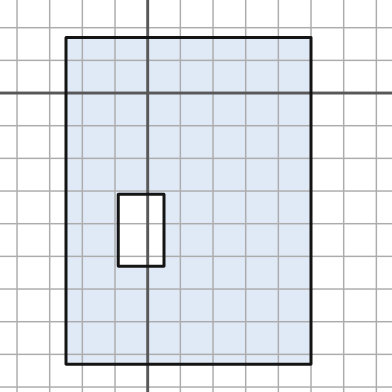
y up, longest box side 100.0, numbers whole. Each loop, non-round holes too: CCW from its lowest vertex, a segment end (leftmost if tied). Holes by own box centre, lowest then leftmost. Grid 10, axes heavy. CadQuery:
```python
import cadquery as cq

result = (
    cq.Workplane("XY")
    .moveTo(-25.0, -83.0)
    .lineTo(50.0, -83.0)
    .lineTo(50.0, 17.0)
    .lineTo(-25.0, 17.0)
    .close()
    .moveTo(-9.0, -53.0)
    .lineTo(5.0, -53.0)
    .lineTo(5.0, -31.0)
    .lineTo(-9.0, -31.0)
    .close()
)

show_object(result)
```